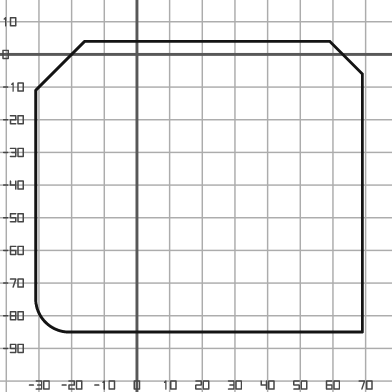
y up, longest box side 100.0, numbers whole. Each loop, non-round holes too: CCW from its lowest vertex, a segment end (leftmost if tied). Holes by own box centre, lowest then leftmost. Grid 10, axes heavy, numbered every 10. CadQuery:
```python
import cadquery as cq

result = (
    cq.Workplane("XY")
    .moveTo(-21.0, -85.0)
    .lineTo(69.0, -85.0)
    .lineTo(69.0, -6.0)
    .lineTo(59.0, 4.0)
    .lineTo(-16.0, 4.0)
    .lineTo(-31.0, -11.0)
    .lineTo(-31.0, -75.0)
    .threePointArc((-28.0, -82.0), (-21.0, -85.0))
    .close()
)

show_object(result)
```